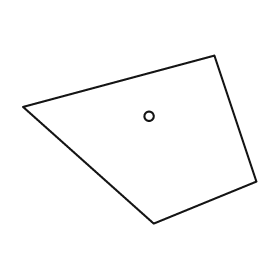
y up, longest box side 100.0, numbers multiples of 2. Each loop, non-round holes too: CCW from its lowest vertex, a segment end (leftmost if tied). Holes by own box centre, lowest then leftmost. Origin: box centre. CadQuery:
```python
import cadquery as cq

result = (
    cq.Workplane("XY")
    .moveTo(6.0, -36.0)
    .lineTo(50.0, -18.0)
    .lineTo(32.0, 36.0)
    .lineTo(-50.0, 14.0)
    .close()
    .moveTo(4.0, 10.0)
    .circle(2.0)
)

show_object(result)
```